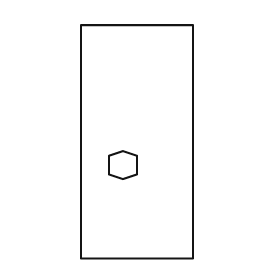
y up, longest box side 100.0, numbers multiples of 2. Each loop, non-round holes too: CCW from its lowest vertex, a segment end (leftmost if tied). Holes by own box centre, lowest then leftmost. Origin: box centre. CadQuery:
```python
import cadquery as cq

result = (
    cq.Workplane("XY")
    .moveTo(-24.0, -50.0)
    .lineTo(24.0, -50.0)
    .lineTo(24.0, 50.0)
    .lineTo(-24.0, 50.0)
    .close()
    .moveTo(-6.0, -16.0)
    .lineTo(0.0, -14.0)
    .lineTo(0.0, -6.0)
    .lineTo(-6.0, -4.0)
    .lineTo(-12.0, -6.0)
    .lineTo(-12.0, -14.0)
    .close()
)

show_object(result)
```